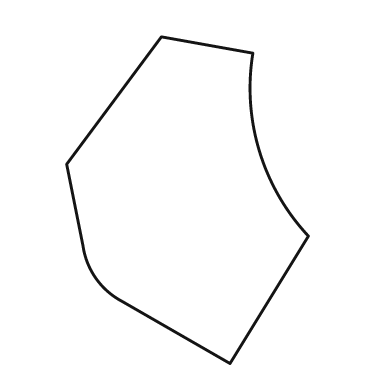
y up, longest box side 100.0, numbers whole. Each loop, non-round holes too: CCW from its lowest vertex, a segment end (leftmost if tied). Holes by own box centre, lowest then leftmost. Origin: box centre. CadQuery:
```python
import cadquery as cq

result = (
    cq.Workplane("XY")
    .moveTo(13.0, -50.0)
    .lineTo(37.0, -11.0)
    .threePointArc((22.0, 15.0), (20.0, 45.0))
    .lineTo(-8.0, 50.0)
    .lineTo(-37.0, 11.0)
    .lineTo(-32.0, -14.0)
    .threePointArc((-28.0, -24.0), (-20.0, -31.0))
    .close()
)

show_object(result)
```